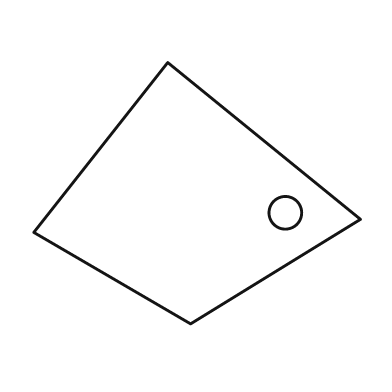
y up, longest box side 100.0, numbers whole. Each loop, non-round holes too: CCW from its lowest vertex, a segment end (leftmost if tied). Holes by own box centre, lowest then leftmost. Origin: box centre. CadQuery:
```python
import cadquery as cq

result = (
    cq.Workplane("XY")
    .moveTo(-2.0, -40.0)
    .lineTo(50.0, -8.0)
    .lineTo(-9.0, 40.0)
    .lineTo(-50.0, -12.0)
    .close()
    .moveTo(27.0, -6.0)
    .circle(5.0)
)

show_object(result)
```